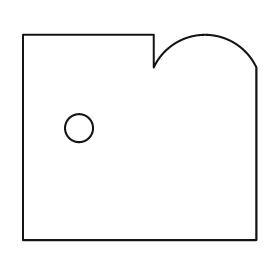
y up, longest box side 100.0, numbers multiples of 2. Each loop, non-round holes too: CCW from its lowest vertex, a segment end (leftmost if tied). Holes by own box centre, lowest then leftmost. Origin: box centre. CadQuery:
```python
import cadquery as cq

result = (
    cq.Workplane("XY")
    .moveTo(-50.0, -44.0)
    .lineTo(50.0, -44.0)
    .lineTo(50.0, 30.0)
    .threePointArc((28.0, 44.0), (6.0, 30.0))
    .lineTo(6.0, 44.0)
    .lineTo(-50.0, 44.0)
    .close()
    .moveTo(-26.0, 4.0)
    .circle(6.0)
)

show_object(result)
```